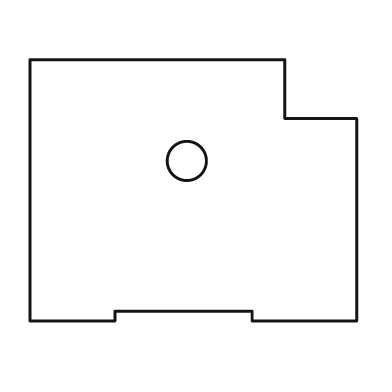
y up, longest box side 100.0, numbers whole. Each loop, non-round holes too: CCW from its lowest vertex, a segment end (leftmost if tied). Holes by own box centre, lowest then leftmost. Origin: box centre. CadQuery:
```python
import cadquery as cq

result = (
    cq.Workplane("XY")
    .moveTo(-50.0, -40.0)
    .lineTo(-24.0, -40.0)
    .lineTo(-24.0, -37.0)
    .lineTo(18.0, -37.0)
    .lineTo(18.0, -40.0)
    .lineTo(50.0, -40.0)
    .lineTo(50.0, 22.0)
    .lineTo(28.0, 22.0)
    .lineTo(28.0, 40.0)
    .lineTo(-50.0, 40.0)
    .close()
    .moveTo(-2.0, 9.0)
    .circle(6.0)
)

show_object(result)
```